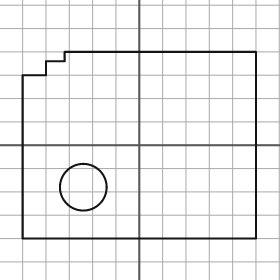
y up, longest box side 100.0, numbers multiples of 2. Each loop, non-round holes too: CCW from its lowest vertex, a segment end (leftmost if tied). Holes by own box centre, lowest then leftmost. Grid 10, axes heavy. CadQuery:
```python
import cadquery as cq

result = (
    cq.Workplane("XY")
    .moveTo(-50.0, -40.0)
    .lineTo(50.0, -40.0)
    .lineTo(50.0, 40.0)
    .lineTo(-32.0, 40.0)
    .lineTo(-32.0, 36.0)
    .lineTo(-40.0, 36.0)
    .lineTo(-40.0, 30.0)
    .lineTo(-50.0, 30.0)
    .close()
    .moveTo(-24.0, -18.0)
    .circle(10.0)
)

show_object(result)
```